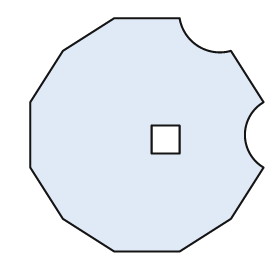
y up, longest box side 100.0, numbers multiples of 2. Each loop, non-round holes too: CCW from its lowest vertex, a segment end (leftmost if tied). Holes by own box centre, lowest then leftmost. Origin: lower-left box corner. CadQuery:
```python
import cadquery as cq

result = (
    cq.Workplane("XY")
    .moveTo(36.0, 0.0)
    .lineTo(64.0, 0.0)
    .lineTo(86.0, 14.0)
    .lineTo(100.0, 36.0)
    .threePointArc((92.0, 50.0), (100.0, 64.0))
    .lineTo(86.0, 86.0)
    .threePointArc((72.0, 88.0), (64.0, 100.0))
    .lineTo(36.0, 100.0)
    .lineTo(14.0, 86.0)
    .lineTo(0.0, 64.0)
    .lineTo(0.0, 36.0)
    .lineTo(14.0, 14.0)
    .close()
    .moveTo(52.0, 42.0)
    .lineTo(64.0, 42.0)
    .lineTo(64.0, 54.0)
    .lineTo(52.0, 54.0)
    .close()
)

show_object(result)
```